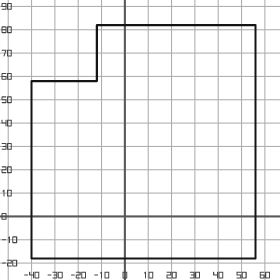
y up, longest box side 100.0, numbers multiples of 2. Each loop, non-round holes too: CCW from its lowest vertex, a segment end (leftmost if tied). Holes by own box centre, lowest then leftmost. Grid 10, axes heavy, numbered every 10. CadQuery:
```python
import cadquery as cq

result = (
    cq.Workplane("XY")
    .moveTo(-40.0, -18.0)
    .lineTo(56.0, -18.0)
    .lineTo(56.0, 82.0)
    .lineTo(-12.0, 82.0)
    .lineTo(-12.0, 58.0)
    .lineTo(-40.0, 58.0)
    .close()
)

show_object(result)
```